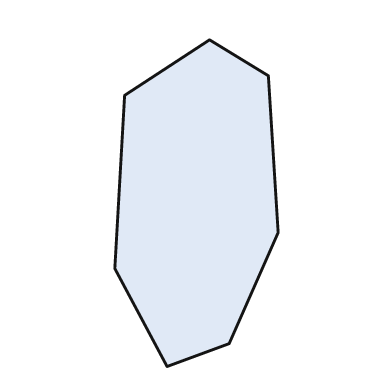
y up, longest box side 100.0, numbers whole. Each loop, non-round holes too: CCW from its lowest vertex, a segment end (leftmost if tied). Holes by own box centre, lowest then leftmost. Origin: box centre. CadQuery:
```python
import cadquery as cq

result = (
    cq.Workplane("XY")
    .moveTo(-9.0, -50.0)
    .lineTo(10.0, -43.0)
    .lineTo(25.0, -9.0)
    .lineTo(22.0, 39.0)
    .lineTo(4.0, 50.0)
    .lineTo(-22.0, 33.0)
    .lineTo(-25.0, -20.0)
    .close()
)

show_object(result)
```